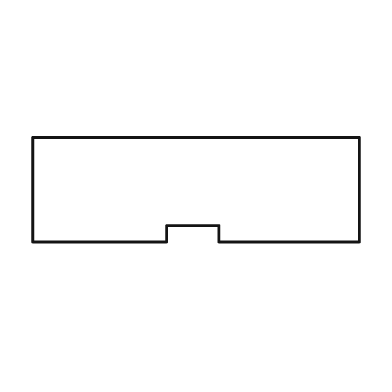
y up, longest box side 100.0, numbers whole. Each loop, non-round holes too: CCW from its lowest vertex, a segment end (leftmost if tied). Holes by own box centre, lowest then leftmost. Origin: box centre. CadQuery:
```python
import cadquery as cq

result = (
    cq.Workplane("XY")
    .moveTo(-50.0, -16.0)
    .lineTo(-9.0, -16.0)
    .lineTo(-9.0, -11.0)
    .lineTo(7.0, -11.0)
    .lineTo(7.0, -16.0)
    .lineTo(50.0, -16.0)
    .lineTo(50.0, 16.0)
    .lineTo(-50.0, 16.0)
    .close()
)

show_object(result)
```